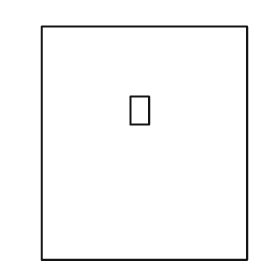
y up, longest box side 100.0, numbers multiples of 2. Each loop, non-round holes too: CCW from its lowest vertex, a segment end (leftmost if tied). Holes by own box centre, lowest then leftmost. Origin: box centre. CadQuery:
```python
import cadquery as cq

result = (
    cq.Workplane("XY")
    .moveTo(-44.0, -50.0)
    .lineTo(44.0, -50.0)
    .lineTo(44.0, 50.0)
    .lineTo(-44.0, 50.0)
    .close()
    .moveTo(-6.0, 8.0)
    .lineTo(2.0, 8.0)
    .lineTo(2.0, 20.0)
    .lineTo(-6.0, 20.0)
    .close()
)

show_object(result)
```